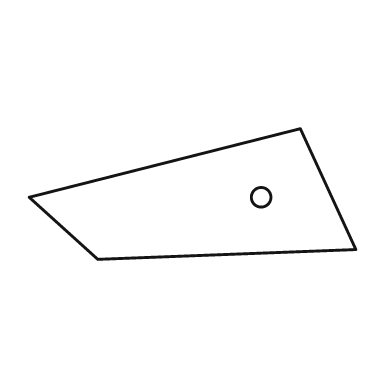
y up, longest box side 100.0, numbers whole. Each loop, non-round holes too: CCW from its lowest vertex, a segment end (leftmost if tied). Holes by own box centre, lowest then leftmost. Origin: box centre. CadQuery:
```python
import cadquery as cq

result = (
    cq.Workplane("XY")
    .moveTo(-29.0, -20.0)
    .lineTo(50.0, -17.0)
    .lineTo(33.0, 20.0)
    .lineTo(-50.0, -1.0)
    .close()
    .moveTo(21.0, -1.0)
    .circle(3.0)
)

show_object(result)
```